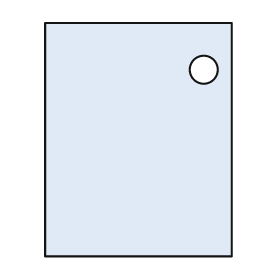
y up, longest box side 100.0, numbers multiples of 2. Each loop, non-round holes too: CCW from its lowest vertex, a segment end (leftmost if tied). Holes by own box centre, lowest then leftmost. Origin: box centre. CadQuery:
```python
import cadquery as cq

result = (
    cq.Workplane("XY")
    .moveTo(-40.0, -50.0)
    .lineTo(40.0, -50.0)
    .lineTo(40.0, 50.0)
    .lineTo(-40.0, 50.0)
    .close()
    .moveTo(28.0, 30.0)
    .circle(6.0)
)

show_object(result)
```